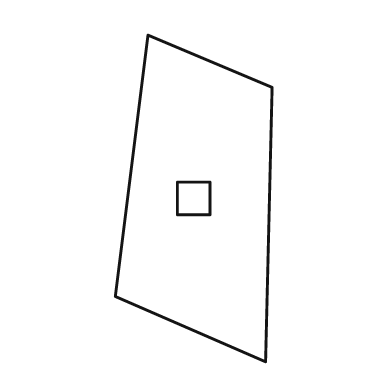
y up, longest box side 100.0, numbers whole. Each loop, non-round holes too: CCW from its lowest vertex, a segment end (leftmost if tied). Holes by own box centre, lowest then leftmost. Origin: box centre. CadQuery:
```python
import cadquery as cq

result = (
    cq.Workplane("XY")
    .moveTo(22.0, -50.0)
    .lineTo(24.0, 34.0)
    .lineTo(-14.0, 50.0)
    .lineTo(-24.0, -30.0)
    .close()
    .moveTo(-5.0, -5.0)
    .lineTo(5.0, -5.0)
    .lineTo(5.0, 5.0)
    .lineTo(-5.0, 5.0)
    .close()
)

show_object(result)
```